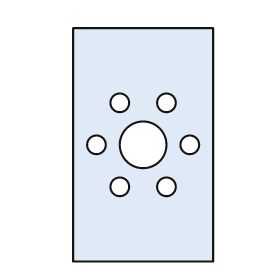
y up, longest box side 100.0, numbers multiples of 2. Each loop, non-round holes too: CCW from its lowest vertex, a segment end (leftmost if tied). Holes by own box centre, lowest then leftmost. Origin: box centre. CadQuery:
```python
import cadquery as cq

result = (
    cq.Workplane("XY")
    .moveTo(-30.0, -50.0)
    .lineTo(30.0, -50.0)
    .lineTo(30.0, 50.0)
    .lineTo(-30.0, 50.0)
    .close()
    .moveTo(-10.0, -18.0)
    .circle(4.0)
    .moveTo(10.0, -18.0)
    .circle(4.0)
    .moveTo(-20.0, 0.0)
    .circle(4.0)
    .moveTo(0.0, 0.0)
    .circle(10.0)
    .moveTo(20.0, 0.0)
    .circle(4.0)
    .moveTo(-10.0, 18.0)
    .circle(4.0)
    .moveTo(10.0, 18.0)
    .circle(4.0)
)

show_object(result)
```